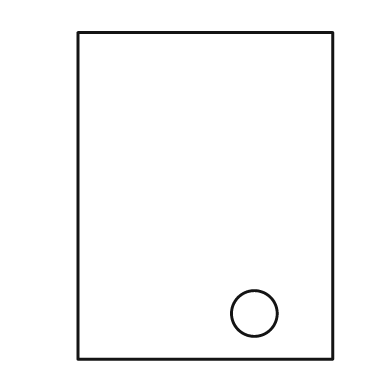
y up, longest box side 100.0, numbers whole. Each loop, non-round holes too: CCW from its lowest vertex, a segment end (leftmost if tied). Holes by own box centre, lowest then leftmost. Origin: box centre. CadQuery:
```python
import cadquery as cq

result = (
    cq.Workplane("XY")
    .moveTo(-39.0, -50.0)
    .lineTo(39.0, -50.0)
    .lineTo(39.0, 50.0)
    .lineTo(-39.0, 50.0)
    .close()
    .moveTo(15.0, -36.0)
    .circle(7.0)
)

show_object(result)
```